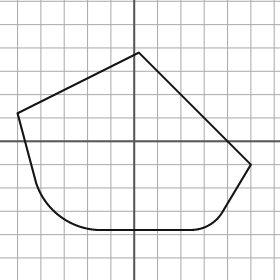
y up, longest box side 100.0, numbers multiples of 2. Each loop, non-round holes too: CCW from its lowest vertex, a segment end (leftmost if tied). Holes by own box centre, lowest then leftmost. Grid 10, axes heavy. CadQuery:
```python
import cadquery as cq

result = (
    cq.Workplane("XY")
    .moveTo(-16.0, -38.0)
    .lineTo(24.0, -38.0)
    .threePointArc((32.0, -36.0), (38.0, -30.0))
    .lineTo(50.0, -10.0)
    .lineTo(2.0, 38.0)
    .lineTo(-50.0, 12.0)
    .lineTo(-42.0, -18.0)
    .threePointArc((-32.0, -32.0), (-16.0, -38.0))
    .close()
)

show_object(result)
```